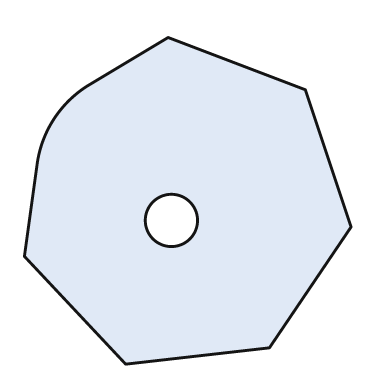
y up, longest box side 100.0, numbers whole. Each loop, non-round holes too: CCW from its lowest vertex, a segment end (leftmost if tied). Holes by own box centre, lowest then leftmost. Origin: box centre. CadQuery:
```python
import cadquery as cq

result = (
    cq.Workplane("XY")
    .moveTo(-19.0, -50.0)
    .lineTo(25.0, -45.0)
    .lineTo(50.0, -8.0)
    .lineTo(36.0, 34.0)
    .lineTo(-6.0, 50.0)
    .lineTo(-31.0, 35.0)
    .threePointArc((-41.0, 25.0), (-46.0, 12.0))
    .lineTo(-50.0, -17.0)
    .close()
    .moveTo(-5.0, -6.0)
    .circle(8.0)
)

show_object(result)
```